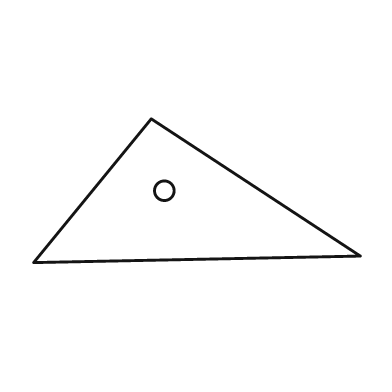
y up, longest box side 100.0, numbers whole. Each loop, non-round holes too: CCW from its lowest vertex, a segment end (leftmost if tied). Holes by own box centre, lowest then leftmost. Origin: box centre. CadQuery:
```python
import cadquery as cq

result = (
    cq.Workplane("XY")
    .moveTo(-50.0, -22.0)
    .lineTo(50.0, -20.0)
    .lineTo(-14.0, 22.0)
    .close()
    .moveTo(-10.0, 0.0)
    .circle(3.0)
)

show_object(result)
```